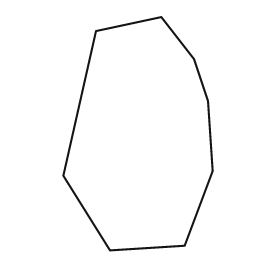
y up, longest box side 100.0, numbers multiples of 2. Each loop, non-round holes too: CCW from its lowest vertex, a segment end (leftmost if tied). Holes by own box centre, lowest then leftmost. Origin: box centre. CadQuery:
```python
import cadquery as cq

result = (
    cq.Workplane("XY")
    .moveTo(-12.0, -50.0)
    .lineTo(20.0, -48.0)
    .lineTo(32.0, -16.0)
    .lineTo(30.0, 14.0)
    .lineTo(24.0, 32.0)
    .lineTo(10.0, 50.0)
    .lineTo(-18.0, 44.0)
    .lineTo(-32.0, -18.0)
    .close()
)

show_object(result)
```